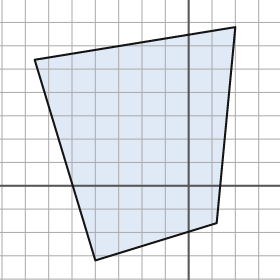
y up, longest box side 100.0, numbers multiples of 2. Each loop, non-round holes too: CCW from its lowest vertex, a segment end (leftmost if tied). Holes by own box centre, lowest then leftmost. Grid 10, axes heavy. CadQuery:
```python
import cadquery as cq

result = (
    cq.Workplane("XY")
    .moveTo(-40.0, -32.0)
    .lineTo(12.0, -16.0)
    .lineTo(20.0, 68.0)
    .lineTo(-66.0, 54.0)
    .close()
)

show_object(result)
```